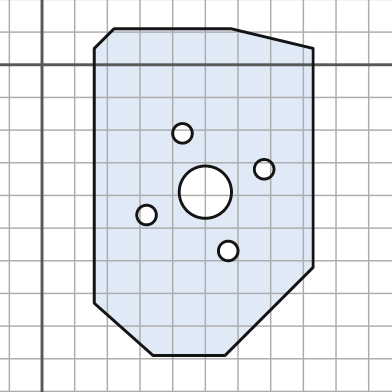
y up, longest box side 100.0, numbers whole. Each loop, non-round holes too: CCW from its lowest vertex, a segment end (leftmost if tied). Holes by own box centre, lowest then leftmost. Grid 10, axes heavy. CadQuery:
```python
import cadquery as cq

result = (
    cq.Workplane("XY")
    .moveTo(34.0, -89.0)
    .lineTo(56.0, -89.0)
    .lineTo(83.0, -62.0)
    .lineTo(83.0, 5.0)
    .lineTo(58.0, 11.0)
    .lineTo(22.0, 11.0)
    .lineTo(16.0, 5.0)
    .lineTo(16.0, -73.0)
    .close()
    .moveTo(57.0, -57.0)
    .circle(3.0)
    .moveTo(32.0, -46.0)
    .circle(3.0)
    .moveTo(50.0, -39.0)
    .circle(8.0)
    .moveTo(68.0, -32.0)
    .circle(3.0)
    .moveTo(43.0, -21.0)
    .circle(3.0)
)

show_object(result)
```